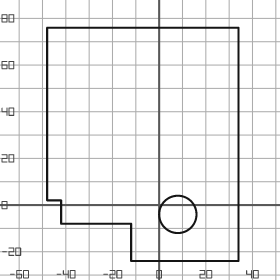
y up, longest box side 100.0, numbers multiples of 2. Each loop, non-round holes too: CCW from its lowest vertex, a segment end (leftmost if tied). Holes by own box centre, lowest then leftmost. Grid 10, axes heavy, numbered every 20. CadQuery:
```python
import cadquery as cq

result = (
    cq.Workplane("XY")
    .moveTo(-12.0, -24.0)
    .lineTo(34.0, -24.0)
    .lineTo(34.0, 76.0)
    .lineTo(-48.0, 76.0)
    .lineTo(-48.0, 2.0)
    .lineTo(-42.0, 2.0)
    .lineTo(-42.0, -8.0)
    .lineTo(-12.0, -8.0)
    .close()
    .moveTo(8.0, -4.0)
    .circle(8.0)
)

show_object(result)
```